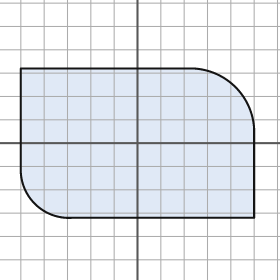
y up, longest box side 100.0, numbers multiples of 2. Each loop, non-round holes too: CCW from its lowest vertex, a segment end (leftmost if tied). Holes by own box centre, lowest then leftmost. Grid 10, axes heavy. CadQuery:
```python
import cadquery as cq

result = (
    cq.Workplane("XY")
    .moveTo(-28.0, -32.0)
    .lineTo(50.0, -32.0)
    .lineTo(50.0, 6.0)
    .threePointArc((42.0, 24.0), (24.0, 32.0))
    .lineTo(-50.0, 32.0)
    .lineTo(-50.0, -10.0)
    .threePointArc((-44.0, -26.0), (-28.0, -32.0))
    .close()
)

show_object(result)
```